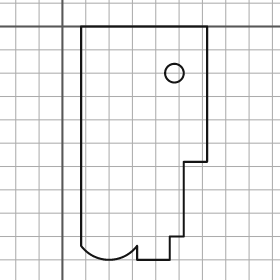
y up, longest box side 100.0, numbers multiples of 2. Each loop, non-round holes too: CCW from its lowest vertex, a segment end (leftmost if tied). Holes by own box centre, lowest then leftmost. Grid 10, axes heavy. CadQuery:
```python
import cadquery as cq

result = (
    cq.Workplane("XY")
    .moveTo(32.0, -100.0)
    .lineTo(46.0, -100.0)
    .lineTo(46.0, -90.0)
    .lineTo(52.0, -90.0)
    .lineTo(52.0, -58.0)
    .lineTo(62.0, -58.0)
    .lineTo(62.0, 0.0)
    .lineTo(8.0, 0.0)
    .lineTo(8.0, -94.0)
    .threePointArc((20.0, -100.0), (32.0, -94.0))
    .close()
    .moveTo(48.0, -20.0)
    .circle(4.0)
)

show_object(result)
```